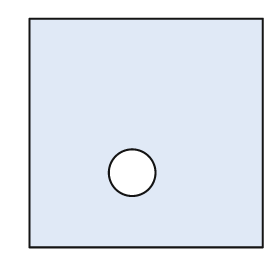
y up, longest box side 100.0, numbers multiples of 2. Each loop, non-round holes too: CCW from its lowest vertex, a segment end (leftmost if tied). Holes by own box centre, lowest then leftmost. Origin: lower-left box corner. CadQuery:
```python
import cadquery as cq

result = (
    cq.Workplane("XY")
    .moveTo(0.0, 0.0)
    .lineTo(100.0, 0.0)
    .lineTo(100.0, 98.0)
    .lineTo(0.0, 98.0)
    .close()
    .moveTo(44.0, 32.0)
    .circle(10.0)
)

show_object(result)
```